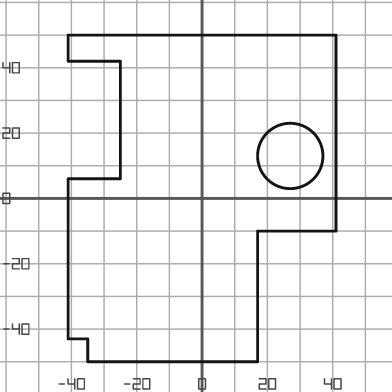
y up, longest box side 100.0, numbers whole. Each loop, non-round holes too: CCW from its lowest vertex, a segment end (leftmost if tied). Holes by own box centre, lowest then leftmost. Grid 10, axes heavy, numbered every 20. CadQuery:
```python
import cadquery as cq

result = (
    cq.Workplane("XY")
    .moveTo(-35.0, -50.0)
    .lineTo(17.0, -50.0)
    .lineTo(17.0, -10.0)
    .lineTo(41.0, -10.0)
    .lineTo(41.0, 50.0)
    .lineTo(-41.0, 50.0)
    .lineTo(-41.0, 42.0)
    .lineTo(-25.0, 42.0)
    .lineTo(-25.0, 6.0)
    .lineTo(-41.0, 6.0)
    .lineTo(-41.0, -43.0)
    .lineTo(-35.0, -43.0)
    .close()
    .moveTo(27.0, 13.0)
    .circle(10.0)
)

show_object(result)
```